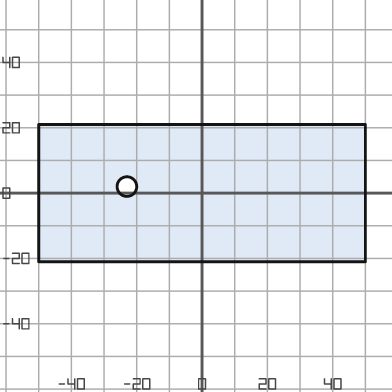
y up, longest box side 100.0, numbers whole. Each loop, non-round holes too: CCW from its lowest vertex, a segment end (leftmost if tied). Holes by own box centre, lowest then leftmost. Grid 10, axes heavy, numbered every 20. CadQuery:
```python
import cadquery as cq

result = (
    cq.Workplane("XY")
    .moveTo(-50.0, -21.0)
    .lineTo(50.0, -21.0)
    .lineTo(50.0, 21.0)
    .lineTo(-50.0, 21.0)
    .close()
    .moveTo(-23.0, 2.0)
    .circle(3.0)
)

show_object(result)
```